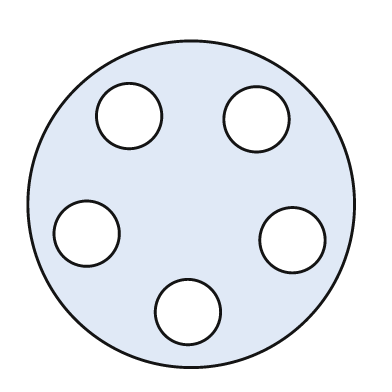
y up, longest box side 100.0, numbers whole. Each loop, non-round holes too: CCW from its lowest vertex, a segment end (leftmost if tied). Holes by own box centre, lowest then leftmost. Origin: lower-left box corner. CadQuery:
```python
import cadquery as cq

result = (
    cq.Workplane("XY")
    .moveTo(50.0, 50.0)
    .circle(50.0)
    .moveTo(49.0, 17.0)
    .circle(10.0)
    .moveTo(81.0, 39.0)
    .circle(10.0)
    .moveTo(18.0, 41.0)
    .circle(10.0)
    .moveTo(70.0, 76.0)
    .circle(10.0)
    .moveTo(31.0, 77.0)
    .circle(10.0)
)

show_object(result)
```